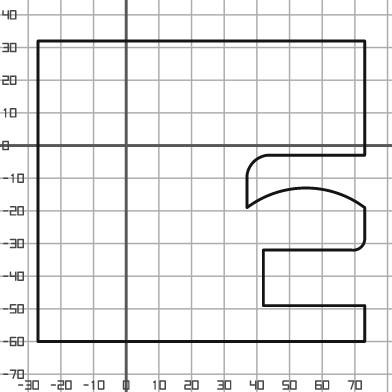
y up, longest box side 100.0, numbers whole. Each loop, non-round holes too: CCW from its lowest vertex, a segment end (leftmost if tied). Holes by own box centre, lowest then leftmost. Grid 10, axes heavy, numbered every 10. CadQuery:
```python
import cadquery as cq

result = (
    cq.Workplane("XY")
    .moveTo(-27.0, -60.0)
    .lineTo(73.0, -60.0)
    .lineTo(73.0, -49.0)
    .lineTo(42.0, -49.0)
    .lineTo(42.0, -32.0)
    .lineTo(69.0, -32.0)
    .threePointArc((72.0, -31.0), (73.0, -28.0))
    .lineTo(73.0, -19.0)
    .threePointArc((55.0, -13.0), (37.0, -19.0))
    .lineTo(37.0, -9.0)
    .threePointArc((39.0, -5.0), (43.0, -3.0))
    .lineTo(73.0, -3.0)
    .lineTo(73.0, 32.0)
    .lineTo(-27.0, 32.0)
    .close()
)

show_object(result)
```